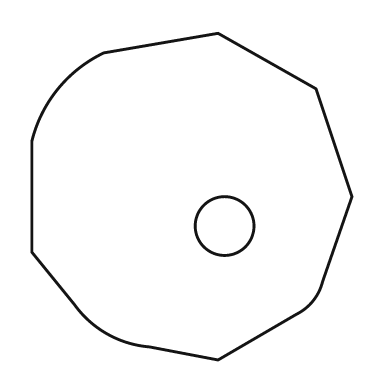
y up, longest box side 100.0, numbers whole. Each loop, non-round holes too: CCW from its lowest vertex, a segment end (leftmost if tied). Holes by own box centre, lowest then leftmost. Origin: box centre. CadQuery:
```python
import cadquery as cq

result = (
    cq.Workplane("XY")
    .moveTo(8.0, -50.0)
    .lineTo(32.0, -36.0)
    .threePointArc((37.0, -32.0), (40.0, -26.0))
    .lineTo(49.0, 0.0)
    .lineTo(38.0, 33.0)
    .lineTo(8.0, 50.0)
    .lineTo(-27.0, 44.0)
    .threePointArc((-41.0, 33.0), (-49.0, 17.0))
    .lineTo(-49.0, -17.0)
    .lineTo(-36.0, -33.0)
    .threePointArc((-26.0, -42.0), (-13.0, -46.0))
    .close()
    .moveTo(10.0, -9.0)
    .circle(9.0)
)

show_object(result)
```